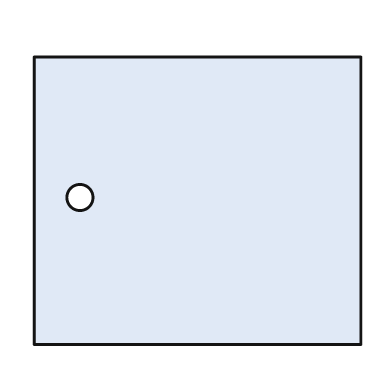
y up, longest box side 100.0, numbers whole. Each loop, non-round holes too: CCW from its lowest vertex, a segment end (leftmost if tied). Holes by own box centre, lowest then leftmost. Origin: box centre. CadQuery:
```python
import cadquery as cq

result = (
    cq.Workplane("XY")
    .moveTo(-50.0, -44.0)
    .lineTo(50.0, -44.0)
    .lineTo(50.0, 44.0)
    .lineTo(-50.0, 44.0)
    .close()
    .moveTo(-36.0, 1.0)
    .circle(4.0)
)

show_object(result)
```